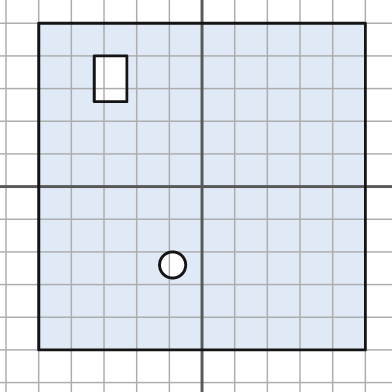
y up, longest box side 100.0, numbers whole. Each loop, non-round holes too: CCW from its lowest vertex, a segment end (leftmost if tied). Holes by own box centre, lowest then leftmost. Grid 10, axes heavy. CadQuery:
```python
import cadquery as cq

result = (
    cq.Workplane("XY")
    .moveTo(-50.0, -50.0)
    .lineTo(50.0, -50.0)
    .lineTo(50.0, 50.0)
    .lineTo(-50.0, 50.0)
    .close()
    .moveTo(-9.0, -24.0)
    .circle(4.0)
    .moveTo(-33.0, 26.0)
    .lineTo(-23.0, 26.0)
    .lineTo(-23.0, 40.0)
    .lineTo(-33.0, 40.0)
    .close()
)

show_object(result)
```